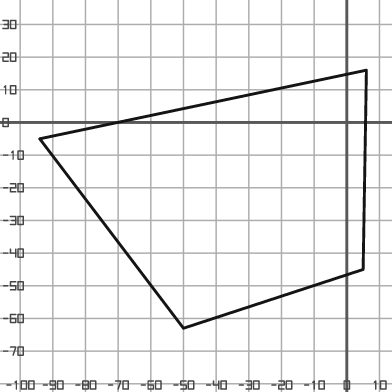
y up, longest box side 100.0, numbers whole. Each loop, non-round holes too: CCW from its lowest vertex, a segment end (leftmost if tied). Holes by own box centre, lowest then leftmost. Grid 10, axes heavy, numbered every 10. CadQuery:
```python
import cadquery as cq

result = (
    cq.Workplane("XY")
    .moveTo(-50.0, -63.0)
    .lineTo(5.0, -45.0)
    .lineTo(6.0, 16.0)
    .lineTo(-94.0, -5.0)
    .close()
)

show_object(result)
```